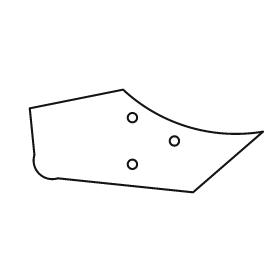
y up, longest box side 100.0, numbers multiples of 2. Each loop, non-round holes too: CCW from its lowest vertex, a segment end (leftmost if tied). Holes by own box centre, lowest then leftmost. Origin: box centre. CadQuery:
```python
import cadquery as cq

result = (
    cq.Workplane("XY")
    .moveTo(20.0, -22.0)
    .lineTo(50.0, 4.0)
    .threePointArc((18.0, 6.0), (-10.0, 22.0))
    .lineTo(-50.0, 14.0)
    .lineTo(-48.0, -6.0)
    .threePointArc((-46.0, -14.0), (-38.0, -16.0))
    .close()
    .moveTo(-6.0, -10.0)
    .circle(2.0)
    .moveTo(12.0, 0.0)
    .circle(2.0)
    .moveTo(-6.0, 10.0)
    .circle(2.0)
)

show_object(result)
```